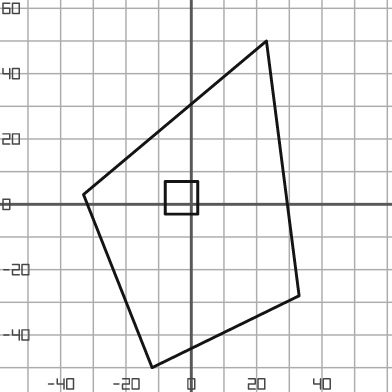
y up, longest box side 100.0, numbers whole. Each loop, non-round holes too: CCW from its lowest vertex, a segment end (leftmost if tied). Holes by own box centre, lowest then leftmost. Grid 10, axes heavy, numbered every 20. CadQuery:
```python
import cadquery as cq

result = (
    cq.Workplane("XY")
    .moveTo(-12.0, -50.0)
    .lineTo(33.0, -28.0)
    .lineTo(23.0, 50.0)
    .lineTo(-33.0, 3.0)
    .close()
    .moveTo(-8.0, -3.0)
    .lineTo(2.0, -3.0)
    .lineTo(2.0, 7.0)
    .lineTo(-8.0, 7.0)
    .close()
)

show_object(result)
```